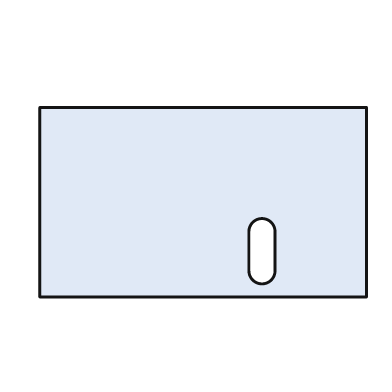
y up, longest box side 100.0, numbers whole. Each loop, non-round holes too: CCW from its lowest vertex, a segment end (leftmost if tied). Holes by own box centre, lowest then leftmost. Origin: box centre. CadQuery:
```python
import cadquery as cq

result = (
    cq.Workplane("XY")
    .moveTo(-50.0, -29.0)
    .lineTo(50.0, -29.0)
    .lineTo(50.0, 29.0)
    .lineTo(-50.0, 29.0)
    .close()
    .moveTo(14.0, -21.0)
    .threePointArc((18.0, -25.0), (22.0, -21.0))
    .lineTo(22.0, -9.0)
    .threePointArc((18.0, -5.0), (14.0, -9.0))
    .close()
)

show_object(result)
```